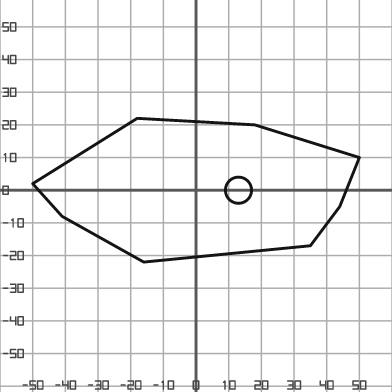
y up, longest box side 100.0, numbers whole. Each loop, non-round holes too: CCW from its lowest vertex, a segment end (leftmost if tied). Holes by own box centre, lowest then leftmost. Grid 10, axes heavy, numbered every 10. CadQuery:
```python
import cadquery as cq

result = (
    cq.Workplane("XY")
    .moveTo(-16.0, -22.0)
    .lineTo(35.0, -17.0)
    .lineTo(44.0, -5.0)
    .lineTo(50.0, 10.0)
    .lineTo(18.0, 20.0)
    .lineTo(-18.0, 22.0)
    .lineTo(-50.0, 2.0)
    .lineTo(-41.0, -8.0)
    .close()
    .moveTo(13.0, 0.0)
    .circle(4.0)
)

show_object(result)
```